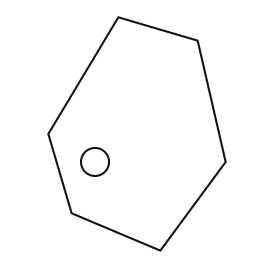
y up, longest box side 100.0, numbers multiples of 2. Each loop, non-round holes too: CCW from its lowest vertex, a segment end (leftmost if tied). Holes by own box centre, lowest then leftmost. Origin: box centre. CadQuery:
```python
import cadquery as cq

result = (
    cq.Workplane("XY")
    .moveTo(10.0, -50.0)
    .lineTo(38.0, -12.0)
    .lineTo(26.0, 40.0)
    .lineTo(-8.0, 50.0)
    .lineTo(-38.0, 0.0)
    .lineTo(-28.0, -34.0)
    .close()
    .moveTo(-18.0, -12.0)
    .circle(6.0)
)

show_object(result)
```